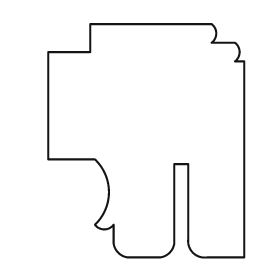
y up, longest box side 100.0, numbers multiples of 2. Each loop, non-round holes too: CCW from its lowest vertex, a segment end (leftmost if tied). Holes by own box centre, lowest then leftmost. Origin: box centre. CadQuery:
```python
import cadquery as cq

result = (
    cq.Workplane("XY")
    .moveTo(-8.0, -50.0)
    .lineTo(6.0, -50.0)
    .threePointArc((10.0, -48.0), (12.0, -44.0))
    .lineTo(12.0, -10.0)
    .lineTo(18.0, -10.0)
    .lineTo(18.0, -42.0)
    .threePointArc((20.0, -48.0), (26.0, -50.0))
    .lineTo(42.0, -50.0)
    .lineTo(42.0, 34.0)
    .lineTo(38.0, 34.0)
    .threePointArc((40.0, 38.0), (38.0, 42.0))
    .lineTo(28.0, 42.0)
    .threePointArc((30.0, 46.0), (28.0, 50.0))
    .lineTo(-24.0, 50.0)
    .lineTo(-24.0, 38.0)
    .lineTo(-42.0, 38.0)
    .lineTo(-42.0, -8.0)
    .lineTo(-22.0, -8.0)
    .threePointArc((-16.0, -22.0), (-22.0, -36.0))
    .threePointArc((-18.0, -38.0), (-14.0, -36.0))
    .lineTo(-14.0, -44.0)
    .threePointArc((-12.0, -48.0), (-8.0, -50.0))
    .close()
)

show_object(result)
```